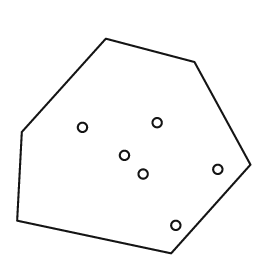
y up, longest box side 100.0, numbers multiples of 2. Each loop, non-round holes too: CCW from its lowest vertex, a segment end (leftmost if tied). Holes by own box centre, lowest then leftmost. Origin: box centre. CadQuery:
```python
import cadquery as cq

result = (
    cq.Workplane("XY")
    .moveTo(16.0, -46.0)
    .lineTo(50.0, -8.0)
    .lineTo(26.0, 36.0)
    .lineTo(-12.0, 46.0)
    .lineTo(-48.0, 6.0)
    .lineTo(-50.0, -32.0)
    .close()
    .moveTo(18.0, -34.0)
    .circle(2.0)
    .moveTo(4.0, -12.0)
    .circle(2.0)
    .moveTo(36.0, -10.0)
    .circle(2.0)
    .moveTo(-4.0, -4.0)
    .circle(2.0)
    .moveTo(-22.0, 8.0)
    .circle(2.0)
    .moveTo(10.0, 10.0)
    .circle(2.0)
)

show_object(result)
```